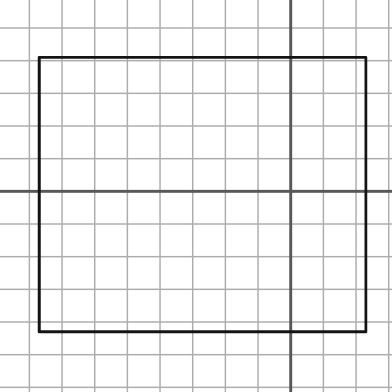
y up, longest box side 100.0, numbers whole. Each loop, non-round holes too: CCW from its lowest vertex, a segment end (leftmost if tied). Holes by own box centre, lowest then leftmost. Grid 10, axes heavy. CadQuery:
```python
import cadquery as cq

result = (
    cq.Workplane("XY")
    .moveTo(-77.0, -43.0)
    .lineTo(23.0, -43.0)
    .lineTo(23.0, 41.0)
    .lineTo(-77.0, 41.0)
    .close()
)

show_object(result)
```